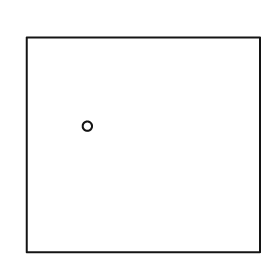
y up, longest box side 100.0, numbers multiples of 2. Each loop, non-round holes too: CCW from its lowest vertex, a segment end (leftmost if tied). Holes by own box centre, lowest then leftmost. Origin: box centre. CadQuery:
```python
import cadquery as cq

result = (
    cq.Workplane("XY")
    .moveTo(-50.0, -46.0)
    .lineTo(50.0, -46.0)
    .lineTo(50.0, 46.0)
    .lineTo(-50.0, 46.0)
    .close()
    .moveTo(-24.0, 8.0)
    .circle(2.0)
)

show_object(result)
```